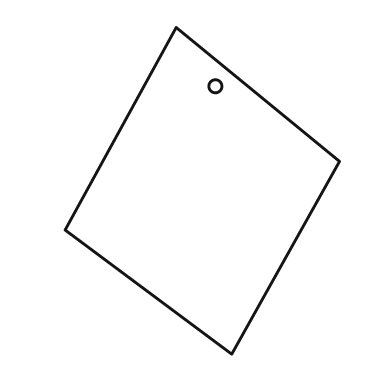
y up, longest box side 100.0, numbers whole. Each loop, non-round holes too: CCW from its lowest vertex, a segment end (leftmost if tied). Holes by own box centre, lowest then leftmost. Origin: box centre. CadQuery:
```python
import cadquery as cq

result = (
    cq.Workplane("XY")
    .moveTo(9.0, -50.0)
    .lineTo(42.0, 9.0)
    .lineTo(-8.0, 50.0)
    .lineTo(-42.0, -12.0)
    .close()
    .moveTo(4.0, 32.0)
    .circle(2.0)
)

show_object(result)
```